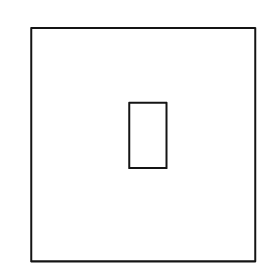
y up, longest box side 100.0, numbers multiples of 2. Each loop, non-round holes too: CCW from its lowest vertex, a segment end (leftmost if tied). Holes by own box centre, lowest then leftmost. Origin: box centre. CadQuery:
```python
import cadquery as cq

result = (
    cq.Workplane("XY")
    .moveTo(-48.0, -50.0)
    .lineTo(48.0, -50.0)
    .lineTo(48.0, 50.0)
    .lineTo(-48.0, 50.0)
    .close()
    .moveTo(-6.0, -10.0)
    .lineTo(10.0, -10.0)
    .lineTo(10.0, 18.0)
    .lineTo(-6.0, 18.0)
    .close()
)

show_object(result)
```